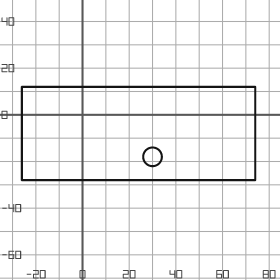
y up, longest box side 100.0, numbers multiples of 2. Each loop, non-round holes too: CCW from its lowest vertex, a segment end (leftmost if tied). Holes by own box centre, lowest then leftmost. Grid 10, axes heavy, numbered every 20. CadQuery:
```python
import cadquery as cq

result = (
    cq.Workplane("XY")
    .moveTo(-26.0, -28.0)
    .lineTo(74.0, -28.0)
    .lineTo(74.0, 12.0)
    .lineTo(-26.0, 12.0)
    .close()
    .moveTo(30.0, -18.0)
    .circle(4.0)
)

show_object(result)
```